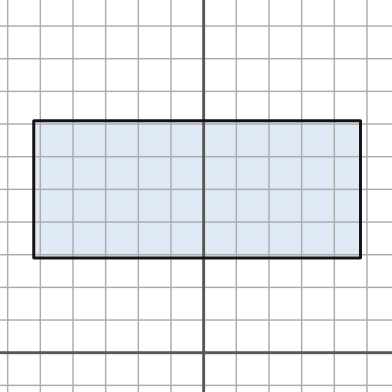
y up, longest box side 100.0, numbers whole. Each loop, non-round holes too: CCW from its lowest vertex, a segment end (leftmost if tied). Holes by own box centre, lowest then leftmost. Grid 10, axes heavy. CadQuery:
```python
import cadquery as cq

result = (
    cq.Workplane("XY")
    .moveTo(-52.0, 29.0)
    .lineTo(48.0, 29.0)
    .lineTo(48.0, 71.0)
    .lineTo(-52.0, 71.0)
    .close()
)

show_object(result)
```